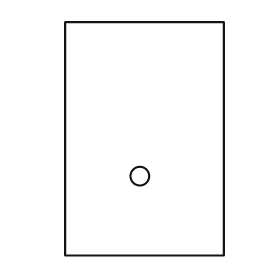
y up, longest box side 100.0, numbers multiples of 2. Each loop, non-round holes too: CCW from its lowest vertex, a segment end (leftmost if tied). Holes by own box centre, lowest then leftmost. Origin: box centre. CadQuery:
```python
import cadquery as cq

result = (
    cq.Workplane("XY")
    .moveTo(-34.0, -50.0)
    .lineTo(34.0, -50.0)
    .lineTo(34.0, 50.0)
    .lineTo(-34.0, 50.0)
    .close()
    .moveTo(-2.0, -16.0)
    .circle(4.0)
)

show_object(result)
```